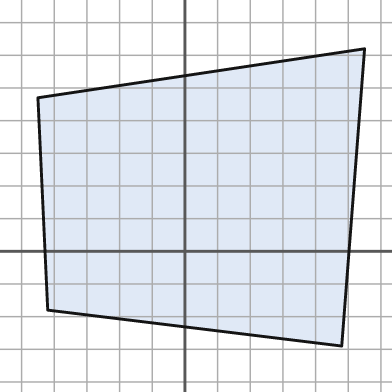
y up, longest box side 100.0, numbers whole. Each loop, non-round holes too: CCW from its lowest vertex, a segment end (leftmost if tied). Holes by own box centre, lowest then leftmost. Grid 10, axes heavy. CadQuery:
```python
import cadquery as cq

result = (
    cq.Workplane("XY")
    .moveTo(48.0, -29.0)
    .lineTo(55.0, 62.0)
    .lineTo(-45.0, 47.0)
    .lineTo(-42.0, -18.0)
    .close()
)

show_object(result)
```